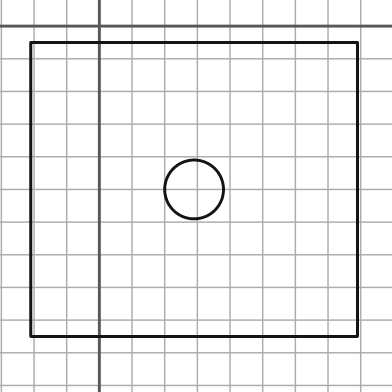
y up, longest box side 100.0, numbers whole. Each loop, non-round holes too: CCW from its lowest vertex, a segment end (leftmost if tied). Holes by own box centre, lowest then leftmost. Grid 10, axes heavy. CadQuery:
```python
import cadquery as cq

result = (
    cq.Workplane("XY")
    .moveTo(-21.0, -95.0)
    .lineTo(79.0, -95.0)
    .lineTo(79.0, -5.0)
    .lineTo(-21.0, -5.0)
    .close()
    .moveTo(29.0, -50.0)
    .circle(9.0)
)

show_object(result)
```